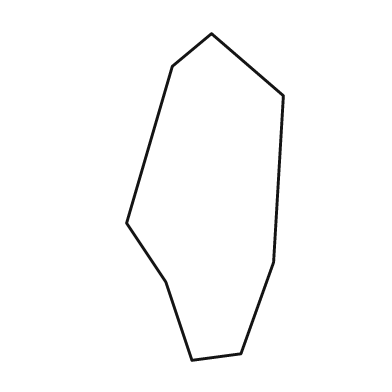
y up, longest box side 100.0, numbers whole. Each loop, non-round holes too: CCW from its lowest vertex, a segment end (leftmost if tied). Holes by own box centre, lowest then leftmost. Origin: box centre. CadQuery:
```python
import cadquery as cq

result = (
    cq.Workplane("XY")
    .moveTo(-4.0, -50.0)
    .lineTo(11.0, -48.0)
    .lineTo(21.0, -20.0)
    .lineTo(24.0, 31.0)
    .lineTo(2.0, 50.0)
    .lineTo(-10.0, 40.0)
    .lineTo(-24.0, -8.0)
    .lineTo(-12.0, -26.0)
    .close()
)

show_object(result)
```